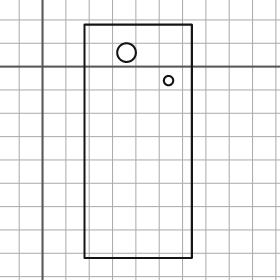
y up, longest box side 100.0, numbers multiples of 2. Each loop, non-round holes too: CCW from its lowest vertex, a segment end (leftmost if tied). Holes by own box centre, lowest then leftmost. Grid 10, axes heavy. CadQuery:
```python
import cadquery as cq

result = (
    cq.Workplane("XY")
    .moveTo(18.0, -82.0)
    .lineTo(64.0, -82.0)
    .lineTo(64.0, 18.0)
    .lineTo(18.0, 18.0)
    .close()
    .moveTo(54.0, -6.0)
    .circle(2.0)
    .moveTo(36.0, 6.0)
    .circle(4.0)
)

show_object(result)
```